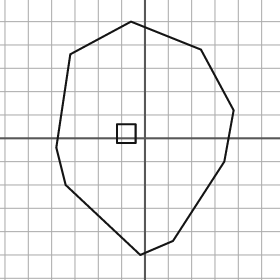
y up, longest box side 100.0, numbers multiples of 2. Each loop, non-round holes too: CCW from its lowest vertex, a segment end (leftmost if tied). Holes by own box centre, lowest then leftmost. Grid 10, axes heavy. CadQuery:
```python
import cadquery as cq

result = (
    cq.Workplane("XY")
    .moveTo(-2.0, -50.0)
    .lineTo(12.0, -44.0)
    .lineTo(34.0, -10.0)
    .lineTo(38.0, 12.0)
    .lineTo(24.0, 38.0)
    .lineTo(-6.0, 50.0)
    .lineTo(-32.0, 36.0)
    .lineTo(-38.0, -4.0)
    .lineTo(-34.0, -20.0)
    .close()
    .moveTo(-12.0, -2.0)
    .lineTo(-4.0, -2.0)
    .lineTo(-4.0, 6.0)
    .lineTo(-12.0, 6.0)
    .close()
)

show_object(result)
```